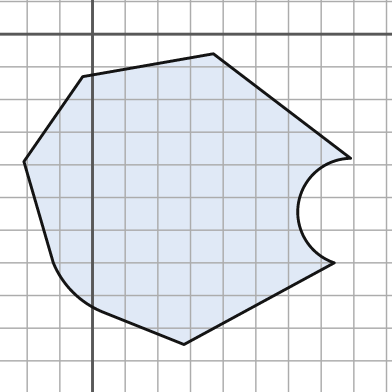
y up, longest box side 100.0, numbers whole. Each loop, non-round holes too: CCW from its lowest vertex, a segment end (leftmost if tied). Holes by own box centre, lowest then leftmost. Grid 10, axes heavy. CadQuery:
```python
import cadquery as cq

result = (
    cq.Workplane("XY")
    .moveTo(28.0, -95.0)
    .lineTo(74.0, -70.0)
    .threePointArc((63.0, -52.0), (79.0, -38.0))
    .lineTo(37.0, -6.0)
    .lineTo(-3.0, -13.0)
    .lineTo(-21.0, -39.0)
    .lineTo(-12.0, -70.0)
    .threePointArc((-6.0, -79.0), (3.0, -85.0))
    .close()
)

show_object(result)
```